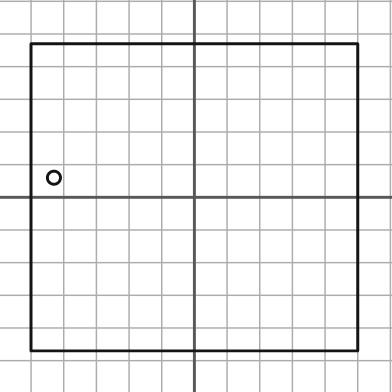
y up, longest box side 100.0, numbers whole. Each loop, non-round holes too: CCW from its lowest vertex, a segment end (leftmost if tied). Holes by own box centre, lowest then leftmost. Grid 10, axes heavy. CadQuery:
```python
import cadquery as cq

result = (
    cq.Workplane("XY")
    .moveTo(-50.0, -47.0)
    .lineTo(50.0, -47.0)
    .lineTo(50.0, 47.0)
    .lineTo(-50.0, 47.0)
    .close()
    .moveTo(-43.0, 6.0)
    .circle(2.0)
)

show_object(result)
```